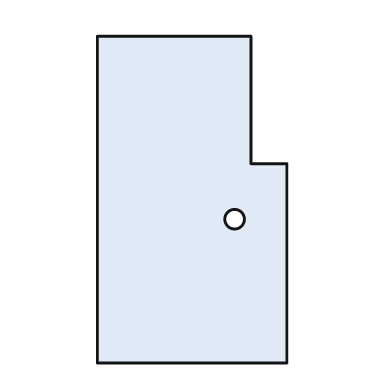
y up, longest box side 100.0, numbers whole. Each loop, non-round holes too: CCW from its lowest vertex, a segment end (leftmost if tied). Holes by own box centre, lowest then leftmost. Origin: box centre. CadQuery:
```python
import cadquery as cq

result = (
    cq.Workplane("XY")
    .moveTo(-29.0, -50.0)
    .lineTo(29.0, -50.0)
    .lineTo(29.0, 11.0)
    .lineTo(18.0, 11.0)
    .lineTo(18.0, 50.0)
    .lineTo(-29.0, 50.0)
    .close()
    .moveTo(13.0, -6.0)
    .circle(3.0)
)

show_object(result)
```